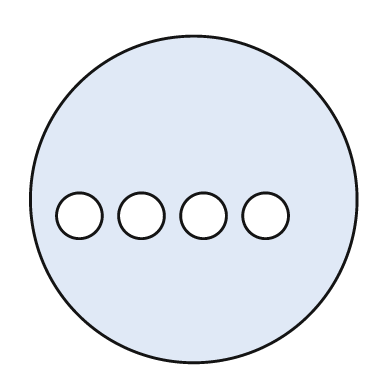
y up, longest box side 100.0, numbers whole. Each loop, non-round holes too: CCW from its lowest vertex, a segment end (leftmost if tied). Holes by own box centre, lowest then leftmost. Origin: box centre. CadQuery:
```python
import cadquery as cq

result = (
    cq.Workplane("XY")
    .moveTo(0.0, 0.0)
    .circle(50.0)
    .moveTo(-35.0, -5.0)
    .circle(7.0)
    .moveTo(-16.0, -5.0)
    .circle(7.0)
    .moveTo(3.0, -5.0)
    .circle(7.0)
    .moveTo(22.0, -5.0)
    .circle(7.0)
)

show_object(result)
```